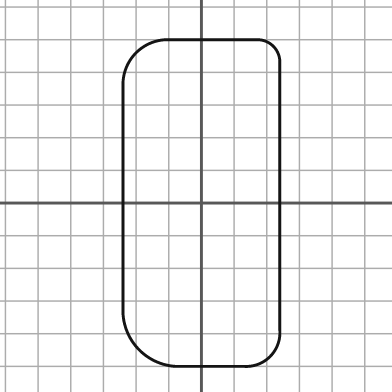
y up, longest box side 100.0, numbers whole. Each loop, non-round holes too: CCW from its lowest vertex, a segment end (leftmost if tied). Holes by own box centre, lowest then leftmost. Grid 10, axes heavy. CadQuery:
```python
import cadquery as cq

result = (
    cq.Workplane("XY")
    .moveTo(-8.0, -50.0)
    .lineTo(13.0, -50.0)
    .threePointArc((21.0, -47.0), (24.0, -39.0))
    .lineTo(24.0, 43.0)
    .threePointArc((22.0, 48.0), (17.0, 50.0))
    .lineTo(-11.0, 50.0)
    .threePointArc((-20.0, 46.0), (-24.0, 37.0))
    .lineTo(-24.0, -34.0)
    .threePointArc((-19.0, -45.0), (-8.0, -50.0))
    .close()
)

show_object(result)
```